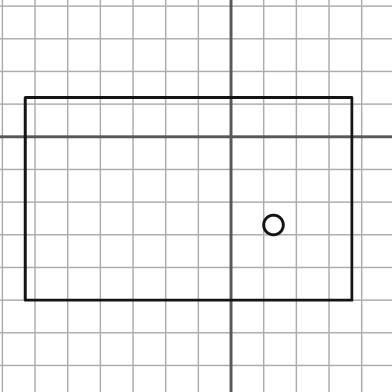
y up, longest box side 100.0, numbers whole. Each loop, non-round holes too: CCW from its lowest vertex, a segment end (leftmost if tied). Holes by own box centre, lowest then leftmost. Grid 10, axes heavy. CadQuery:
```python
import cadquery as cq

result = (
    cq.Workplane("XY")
    .moveTo(-63.0, -50.0)
    .lineTo(37.0, -50.0)
    .lineTo(37.0, 12.0)
    .lineTo(-63.0, 12.0)
    .close()
    .moveTo(13.0, -27.0)
    .circle(3.0)
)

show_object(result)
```